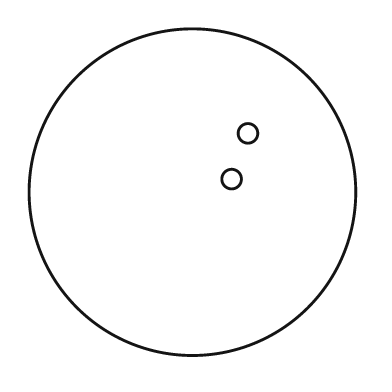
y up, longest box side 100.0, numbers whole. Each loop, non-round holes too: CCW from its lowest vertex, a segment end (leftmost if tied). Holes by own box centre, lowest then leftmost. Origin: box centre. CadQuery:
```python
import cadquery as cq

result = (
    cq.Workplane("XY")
    .moveTo(0.0, 0.0)
    .circle(50.0)
    .moveTo(12.0, 4.0)
    .circle(3.0)
    .moveTo(17.0, 18.0)
    .circle(3.0)
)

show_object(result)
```